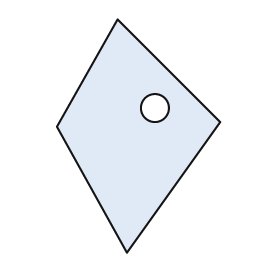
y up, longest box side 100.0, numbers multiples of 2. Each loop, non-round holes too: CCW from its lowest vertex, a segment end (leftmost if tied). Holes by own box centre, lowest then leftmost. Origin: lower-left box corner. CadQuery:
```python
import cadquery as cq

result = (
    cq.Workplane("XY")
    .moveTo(30.0, 0.0)
    .lineTo(70.0, 56.0)
    .lineTo(26.0, 100.0)
    .lineTo(0.0, 54.0)
    .close()
    .moveTo(42.0, 62.0)
    .circle(6.0)
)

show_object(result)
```